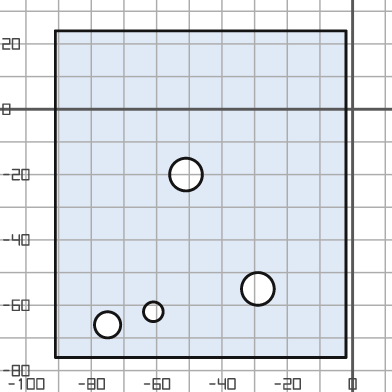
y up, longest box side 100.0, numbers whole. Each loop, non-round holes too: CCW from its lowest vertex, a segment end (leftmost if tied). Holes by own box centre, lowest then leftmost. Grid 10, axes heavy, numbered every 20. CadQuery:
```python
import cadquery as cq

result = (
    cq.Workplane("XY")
    .moveTo(-91.0, -76.0)
    .lineTo(-2.0, -76.0)
    .lineTo(-2.0, 24.0)
    .lineTo(-91.0, 24.0)
    .close()
    .moveTo(-75.0, -66.0)
    .circle(4.0)
    .moveTo(-61.0, -62.0)
    .circle(3.0)
    .moveTo(-29.0, -55.0)
    .circle(5.0)
    .moveTo(-51.0, -20.0)
    .circle(5.0)
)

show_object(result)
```